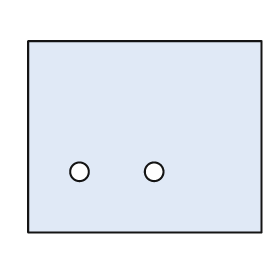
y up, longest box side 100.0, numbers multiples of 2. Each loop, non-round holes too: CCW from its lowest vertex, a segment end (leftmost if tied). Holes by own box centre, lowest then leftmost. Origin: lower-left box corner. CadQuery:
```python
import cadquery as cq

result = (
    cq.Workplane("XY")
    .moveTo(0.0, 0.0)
    .lineTo(100.0, 0.0)
    .lineTo(100.0, 82.0)
    .lineTo(0.0, 82.0)
    .close()
    .moveTo(22.0, 26.0)
    .circle(4.0)
    .moveTo(54.0, 26.0)
    .circle(4.0)
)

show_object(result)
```